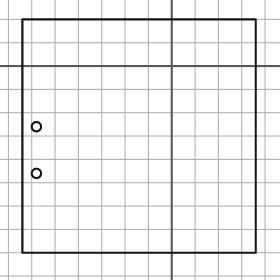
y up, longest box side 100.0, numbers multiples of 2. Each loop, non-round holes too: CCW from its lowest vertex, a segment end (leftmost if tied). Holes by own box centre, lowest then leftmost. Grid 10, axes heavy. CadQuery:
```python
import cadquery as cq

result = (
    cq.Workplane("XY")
    .moveTo(-64.0, -80.0)
    .lineTo(36.0, -80.0)
    .lineTo(36.0, 20.0)
    .lineTo(-64.0, 20.0)
    .close()
    .moveTo(-58.0, -46.0)
    .circle(2.0)
    .moveTo(-58.0, -26.0)
    .circle(2.0)
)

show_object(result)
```